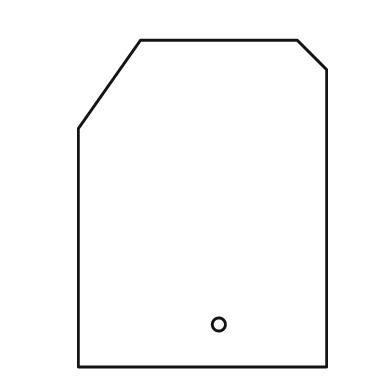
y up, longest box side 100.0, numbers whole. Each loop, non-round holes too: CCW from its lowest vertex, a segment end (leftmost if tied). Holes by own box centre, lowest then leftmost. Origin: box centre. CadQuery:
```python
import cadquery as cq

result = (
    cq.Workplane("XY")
    .moveTo(-38.0, -50.0)
    .lineTo(38.0, -50.0)
    .lineTo(38.0, 41.0)
    .lineTo(29.0, 50.0)
    .lineTo(-19.0, 50.0)
    .lineTo(-38.0, 23.0)
    .close()
    .moveTo(5.0, -37.0)
    .circle(2.0)
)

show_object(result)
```